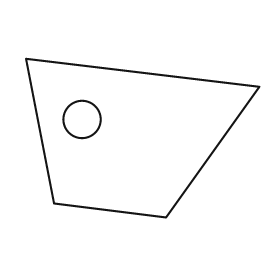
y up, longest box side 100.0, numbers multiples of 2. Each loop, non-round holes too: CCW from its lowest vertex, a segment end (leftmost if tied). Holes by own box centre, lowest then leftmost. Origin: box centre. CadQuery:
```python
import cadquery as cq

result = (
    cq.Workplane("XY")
    .moveTo(10.0, -34.0)
    .lineTo(50.0, 22.0)
    .lineTo(-50.0, 34.0)
    .lineTo(-38.0, -28.0)
    .close()
    .moveTo(-26.0, 8.0)
    .circle(8.0)
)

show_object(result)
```